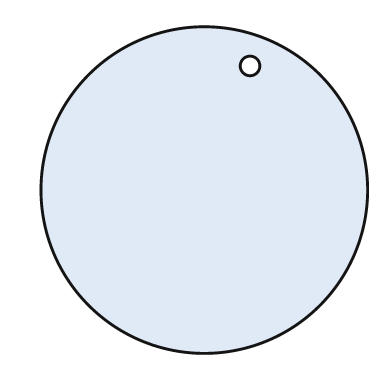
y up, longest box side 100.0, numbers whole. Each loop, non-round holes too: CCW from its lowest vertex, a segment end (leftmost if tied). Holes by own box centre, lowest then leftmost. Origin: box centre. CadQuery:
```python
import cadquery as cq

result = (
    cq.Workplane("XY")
    .moveTo(0.0, 0.0)
    .circle(50.0)
    .moveTo(14.0, 38.0)
    .circle(3.0)
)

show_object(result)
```